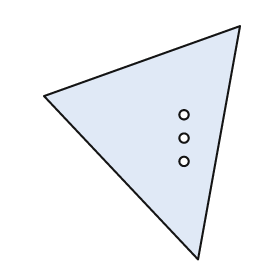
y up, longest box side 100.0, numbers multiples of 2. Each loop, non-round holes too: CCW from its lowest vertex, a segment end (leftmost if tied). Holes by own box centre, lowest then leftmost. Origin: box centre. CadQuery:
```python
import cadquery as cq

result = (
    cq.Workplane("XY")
    .moveTo(24.0, -50.0)
    .lineTo(42.0, 50.0)
    .lineTo(-42.0, 20.0)
    .close()
    .moveTo(18.0, -8.0)
    .circle(2.0)
    .moveTo(18.0, 2.0)
    .circle(2.0)
    .moveTo(18.0, 12.0)
    .circle(2.0)
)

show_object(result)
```